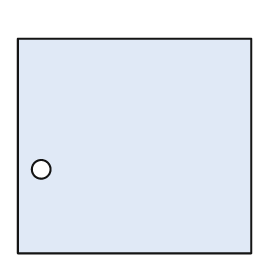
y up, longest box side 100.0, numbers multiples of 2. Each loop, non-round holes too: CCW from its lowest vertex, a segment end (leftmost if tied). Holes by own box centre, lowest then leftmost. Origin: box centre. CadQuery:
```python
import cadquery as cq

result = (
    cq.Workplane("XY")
    .moveTo(-50.0, -46.0)
    .lineTo(50.0, -46.0)
    .lineTo(50.0, 46.0)
    .lineTo(-50.0, 46.0)
    .close()
    .moveTo(-40.0, -10.0)
    .circle(4.0)
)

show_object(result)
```